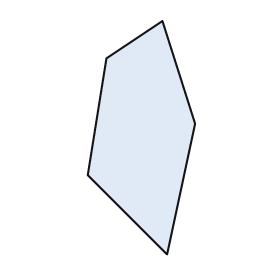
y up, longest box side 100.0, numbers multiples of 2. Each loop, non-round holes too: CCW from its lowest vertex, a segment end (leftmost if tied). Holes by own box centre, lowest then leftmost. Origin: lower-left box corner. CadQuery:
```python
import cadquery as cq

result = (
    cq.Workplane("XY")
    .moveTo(34.0, 0.0)
    .lineTo(46.0, 56.0)
    .lineTo(32.0, 100.0)
    .lineTo(8.0, 84.0)
    .lineTo(0.0, 34.0)
    .close()
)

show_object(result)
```